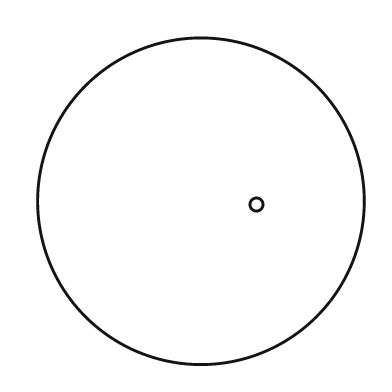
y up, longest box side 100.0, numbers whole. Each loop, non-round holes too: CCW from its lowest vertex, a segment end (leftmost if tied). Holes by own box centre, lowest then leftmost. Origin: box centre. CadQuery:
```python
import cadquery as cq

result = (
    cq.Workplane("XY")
    .moveTo(0.0, 0.0)
    .circle(50.0)
    .moveTo(17.0, -1.0)
    .circle(2.0)
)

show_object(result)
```